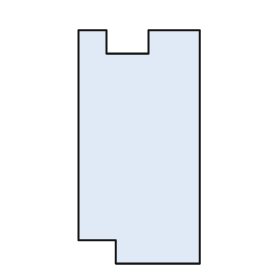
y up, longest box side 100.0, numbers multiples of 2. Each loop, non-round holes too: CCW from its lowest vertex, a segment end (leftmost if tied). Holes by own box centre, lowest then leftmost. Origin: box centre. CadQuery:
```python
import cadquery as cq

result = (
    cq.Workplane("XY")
    .moveTo(-10.0, -50.0)
    .lineTo(26.0, -50.0)
    .lineTo(26.0, 50.0)
    .lineTo(4.0, 50.0)
    .lineTo(4.0, 40.0)
    .lineTo(-14.0, 40.0)
    .lineTo(-14.0, 50.0)
    .lineTo(-26.0, 50.0)
    .lineTo(-26.0, -40.0)
    .lineTo(-10.0, -40.0)
    .close()
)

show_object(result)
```